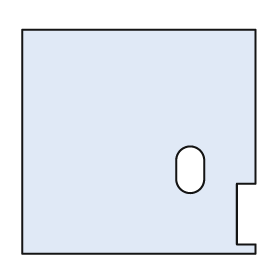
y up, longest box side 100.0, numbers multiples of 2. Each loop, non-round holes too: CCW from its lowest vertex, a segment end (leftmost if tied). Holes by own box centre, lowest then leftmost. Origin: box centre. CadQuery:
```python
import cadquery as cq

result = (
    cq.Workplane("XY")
    .moveTo(-50.0, -48.0)
    .lineTo(50.0, -48.0)
    .lineTo(50.0, -44.0)
    .lineTo(42.0, -44.0)
    .lineTo(42.0, -18.0)
    .lineTo(50.0, -18.0)
    .lineTo(50.0, 48.0)
    .lineTo(-50.0, 48.0)
    .close()
    .moveTo(16.0, -16.0)
    .threePointArc((22.0, -22.0), (28.0, -16.0))
    .lineTo(28.0, -8.0)
    .threePointArc((22.0, -2.0), (16.0, -8.0))
    .close()
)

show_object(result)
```